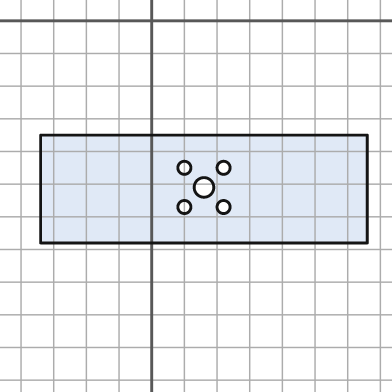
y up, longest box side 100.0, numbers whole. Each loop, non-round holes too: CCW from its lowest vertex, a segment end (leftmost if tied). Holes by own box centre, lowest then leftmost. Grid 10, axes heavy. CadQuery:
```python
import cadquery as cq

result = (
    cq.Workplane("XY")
    .moveTo(-34.0, -68.0)
    .lineTo(66.0, -68.0)
    .lineTo(66.0, -35.0)
    .lineTo(-34.0, -35.0)
    .close()
    .moveTo(10.0, -57.0)
    .circle(2.0)
    .moveTo(22.0, -57.0)
    .circle(2.0)
    .moveTo(16.0, -51.0)
    .circle(3.0)
    .moveTo(10.0, -45.0)
    .circle(2.0)
    .moveTo(22.0, -45.0)
    .circle(2.0)
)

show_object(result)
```